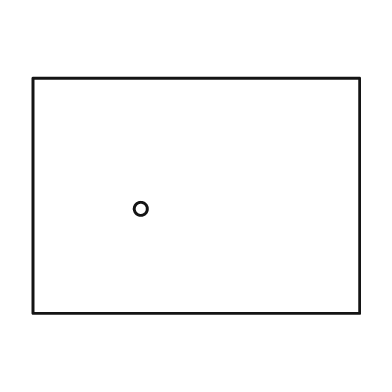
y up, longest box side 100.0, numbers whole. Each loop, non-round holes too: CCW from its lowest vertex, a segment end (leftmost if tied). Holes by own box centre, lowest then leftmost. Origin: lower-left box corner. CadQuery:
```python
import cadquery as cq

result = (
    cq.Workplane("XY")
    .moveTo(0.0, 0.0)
    .lineTo(100.0, 0.0)
    .lineTo(100.0, 72.0)
    .lineTo(0.0, 72.0)
    .close()
    .moveTo(33.0, 32.0)
    .circle(2.0)
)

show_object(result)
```